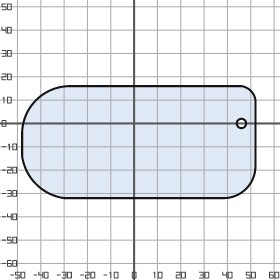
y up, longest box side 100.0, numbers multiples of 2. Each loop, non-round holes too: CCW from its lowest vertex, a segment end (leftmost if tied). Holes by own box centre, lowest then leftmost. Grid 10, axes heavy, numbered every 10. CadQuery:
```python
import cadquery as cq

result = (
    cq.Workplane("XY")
    .moveTo(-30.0, -32.0)
    .lineTo(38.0, -32.0)
    .threePointArc((48.0, -28.0), (52.0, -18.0))
    .lineTo(52.0, 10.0)
    .threePointArc((50.0, 14.0), (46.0, 16.0))
    .lineTo(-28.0, 16.0)
    .threePointArc((-42.0, 10.0), (-48.0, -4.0))
    .lineTo(-48.0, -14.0)
    .threePointArc((-42.0, -26.0), (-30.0, -32.0))
    .close()
    .moveTo(46.0, 0.0)
    .circle(2.0)
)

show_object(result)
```